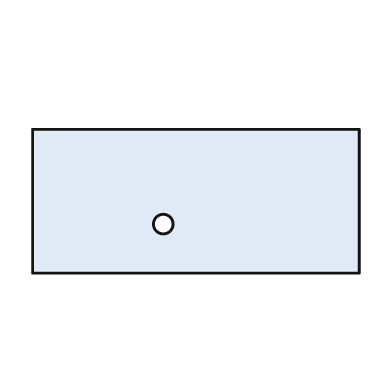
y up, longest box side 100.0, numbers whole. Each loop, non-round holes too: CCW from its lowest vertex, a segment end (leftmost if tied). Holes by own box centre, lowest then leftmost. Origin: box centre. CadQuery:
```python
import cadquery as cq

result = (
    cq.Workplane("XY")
    .moveTo(-50.0, -22.0)
    .lineTo(50.0, -22.0)
    .lineTo(50.0, 22.0)
    .lineTo(-50.0, 22.0)
    .close()
    .moveTo(-10.0, -7.0)
    .circle(3.0)
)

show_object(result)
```